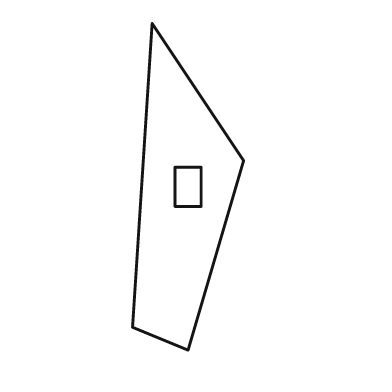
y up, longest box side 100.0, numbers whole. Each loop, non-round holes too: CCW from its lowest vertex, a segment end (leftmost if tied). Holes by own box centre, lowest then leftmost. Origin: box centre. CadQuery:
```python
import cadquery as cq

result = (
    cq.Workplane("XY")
    .moveTo(0.0, -50.0)
    .lineTo(17.0, 8.0)
    .lineTo(-11.0, 50.0)
    .lineTo(-17.0, -43.0)
    .close()
    .moveTo(-4.0, -6.0)
    .lineTo(4.0, -6.0)
    .lineTo(4.0, 6.0)
    .lineTo(-4.0, 6.0)
    .close()
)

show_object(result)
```